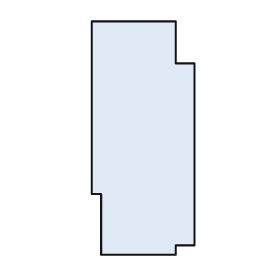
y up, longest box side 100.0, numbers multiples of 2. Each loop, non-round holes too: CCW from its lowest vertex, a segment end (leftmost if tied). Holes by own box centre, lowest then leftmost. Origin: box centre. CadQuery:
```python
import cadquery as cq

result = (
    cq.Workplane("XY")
    .moveTo(-18.0, -50.0)
    .lineTo(14.0, -50.0)
    .lineTo(14.0, -46.0)
    .lineTo(22.0, -46.0)
    .lineTo(22.0, 32.0)
    .lineTo(14.0, 32.0)
    .lineTo(14.0, 50.0)
    .lineTo(-22.0, 50.0)
    .lineTo(-22.0, -24.0)
    .lineTo(-18.0, -24.0)
    .close()
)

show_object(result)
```